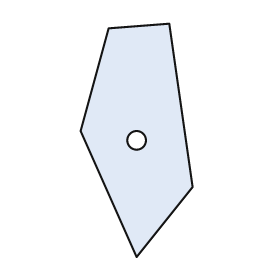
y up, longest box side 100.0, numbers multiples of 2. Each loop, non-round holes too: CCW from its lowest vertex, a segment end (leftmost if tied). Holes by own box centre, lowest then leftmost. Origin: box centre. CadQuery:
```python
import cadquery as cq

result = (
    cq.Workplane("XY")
    .moveTo(0.0, -50.0)
    .lineTo(24.0, -20.0)
    .lineTo(14.0, 50.0)
    .lineTo(-12.0, 48.0)
    .lineTo(-24.0, 4.0)
    .close()
    .moveTo(0.0, 0.0)
    .circle(4.0)
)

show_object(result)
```